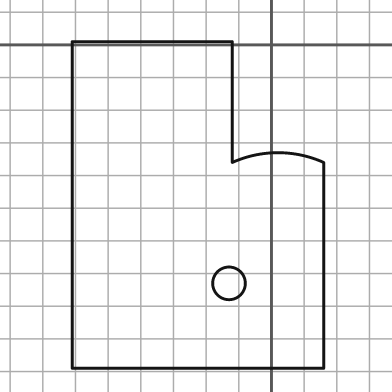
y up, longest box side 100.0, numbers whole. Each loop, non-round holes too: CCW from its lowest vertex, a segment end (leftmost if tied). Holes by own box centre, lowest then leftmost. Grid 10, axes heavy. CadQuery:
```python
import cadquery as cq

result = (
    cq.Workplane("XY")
    .moveTo(-61.0, -99.0)
    .lineTo(16.0, -99.0)
    .lineTo(16.0, -36.0)
    .threePointArc((2.0, -33.0), (-12.0, -36.0))
    .lineTo(-12.0, 1.0)
    .lineTo(-61.0, 1.0)
    .close()
    .moveTo(-13.0, -73.0)
    .circle(5.0)
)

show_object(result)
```